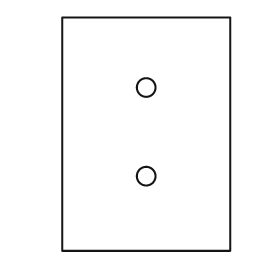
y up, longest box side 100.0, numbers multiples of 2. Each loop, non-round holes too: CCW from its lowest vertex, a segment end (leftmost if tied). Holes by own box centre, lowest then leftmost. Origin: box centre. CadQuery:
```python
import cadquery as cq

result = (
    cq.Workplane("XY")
    .moveTo(-36.0, -50.0)
    .lineTo(36.0, -50.0)
    .lineTo(36.0, 50.0)
    .lineTo(-36.0, 50.0)
    .close()
    .moveTo(0.0, -18.0)
    .circle(4.0)
    .moveTo(0.0, 20.0)
    .circle(4.0)
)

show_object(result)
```